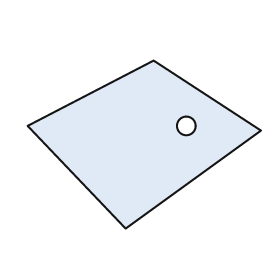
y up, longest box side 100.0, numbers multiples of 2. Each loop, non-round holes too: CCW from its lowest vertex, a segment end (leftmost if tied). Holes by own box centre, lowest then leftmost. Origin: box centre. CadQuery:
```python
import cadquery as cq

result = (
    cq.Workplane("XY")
    .moveTo(-8.0, -36.0)
    .lineTo(50.0, 6.0)
    .lineTo(4.0, 36.0)
    .lineTo(-50.0, 8.0)
    .close()
    .moveTo(18.0, 8.0)
    .circle(4.0)
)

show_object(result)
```